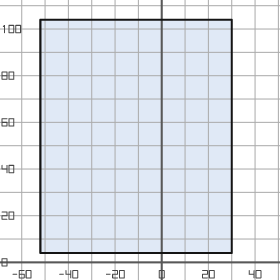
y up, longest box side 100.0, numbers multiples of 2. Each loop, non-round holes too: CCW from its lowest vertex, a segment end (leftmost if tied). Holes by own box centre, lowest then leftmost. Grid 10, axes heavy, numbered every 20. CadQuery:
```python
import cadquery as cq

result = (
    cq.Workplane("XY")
    .moveTo(-52.0, 4.0)
    .lineTo(30.0, 4.0)
    .lineTo(30.0, 104.0)
    .lineTo(-52.0, 104.0)
    .close()
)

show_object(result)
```